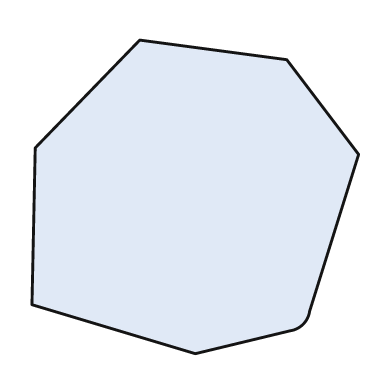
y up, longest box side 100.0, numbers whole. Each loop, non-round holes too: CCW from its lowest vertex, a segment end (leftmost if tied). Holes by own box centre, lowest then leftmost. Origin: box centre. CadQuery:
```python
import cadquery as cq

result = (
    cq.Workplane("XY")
    .moveTo(0.0, -48.0)
    .lineTo(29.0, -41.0)
    .threePointArc((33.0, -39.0), (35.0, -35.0))
    .lineTo(50.0, 13.0)
    .lineTo(28.0, 42.0)
    .lineTo(-17.0, 48.0)
    .lineTo(-49.0, 15.0)
    .lineTo(-50.0, -33.0)
    .close()
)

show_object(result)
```